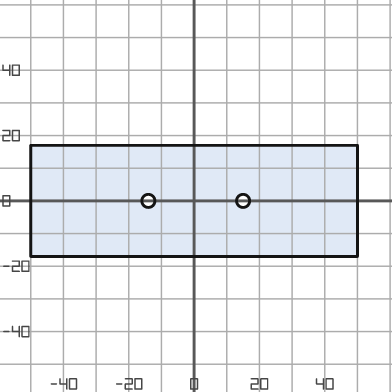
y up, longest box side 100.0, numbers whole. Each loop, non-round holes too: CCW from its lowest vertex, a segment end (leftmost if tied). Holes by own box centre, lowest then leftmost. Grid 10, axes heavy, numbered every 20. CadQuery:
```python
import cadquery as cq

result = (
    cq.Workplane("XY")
    .moveTo(-50.0, -17.0)
    .lineTo(50.0, -17.0)
    .lineTo(50.0, 17.0)
    .lineTo(-50.0, 17.0)
    .close()
    .moveTo(-14.0, 0.0)
    .circle(2.0)
    .moveTo(15.0, 0.0)
    .circle(2.0)
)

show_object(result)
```